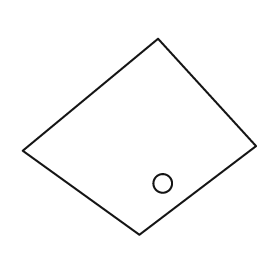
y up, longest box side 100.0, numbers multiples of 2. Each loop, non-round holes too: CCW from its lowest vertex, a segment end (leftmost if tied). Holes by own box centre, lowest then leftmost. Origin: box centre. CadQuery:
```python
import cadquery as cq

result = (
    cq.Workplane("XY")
    .moveTo(0.0, -42.0)
    .lineTo(50.0, -4.0)
    .lineTo(8.0, 42.0)
    .lineTo(-50.0, -6.0)
    .close()
    .moveTo(10.0, -20.0)
    .circle(4.0)
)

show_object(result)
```